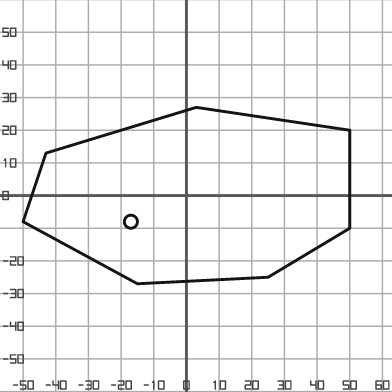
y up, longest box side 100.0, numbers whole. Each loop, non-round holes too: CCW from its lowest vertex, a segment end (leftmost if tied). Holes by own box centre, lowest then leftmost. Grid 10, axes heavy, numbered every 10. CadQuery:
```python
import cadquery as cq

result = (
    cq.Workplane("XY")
    .moveTo(-15.0, -27.0)
    .lineTo(25.0, -25.0)
    .lineTo(50.0, -10.0)
    .lineTo(50.0, 20.0)
    .lineTo(3.0, 27.0)
    .lineTo(-43.0, 13.0)
    .lineTo(-50.0, -8.0)
    .close()
    .moveTo(-17.0, -8.0)
    .circle(2.0)
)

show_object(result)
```